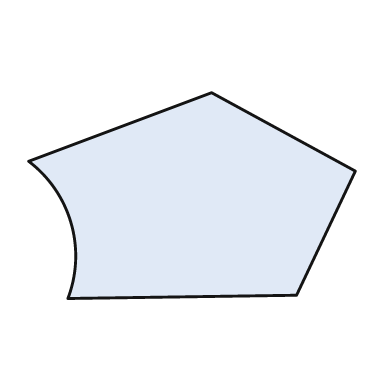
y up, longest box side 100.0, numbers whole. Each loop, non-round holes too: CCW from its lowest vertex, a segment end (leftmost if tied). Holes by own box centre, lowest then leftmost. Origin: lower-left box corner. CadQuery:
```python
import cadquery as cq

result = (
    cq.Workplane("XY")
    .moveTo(12.0, 0.0)
    .lineTo(82.0, 1.0)
    .lineTo(100.0, 39.0)
    .lineTo(56.0, 63.0)
    .lineTo(0.0, 42.0)
    .threePointArc((13.0, 23.0), (12.0, 0.0))
    .close()
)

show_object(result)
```